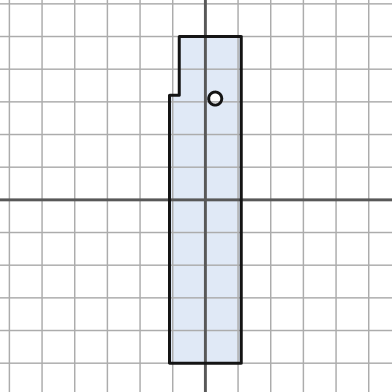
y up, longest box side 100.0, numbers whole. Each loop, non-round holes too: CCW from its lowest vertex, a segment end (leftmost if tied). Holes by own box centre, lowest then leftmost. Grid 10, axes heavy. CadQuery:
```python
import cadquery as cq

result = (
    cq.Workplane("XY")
    .moveTo(-11.0, -50.0)
    .lineTo(11.0, -50.0)
    .lineTo(11.0, 50.0)
    .lineTo(-8.0, 50.0)
    .lineTo(-8.0, 32.0)
    .lineTo(-11.0, 32.0)
    .close()
    .moveTo(3.0, 31.0)
    .circle(2.0)
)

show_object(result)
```